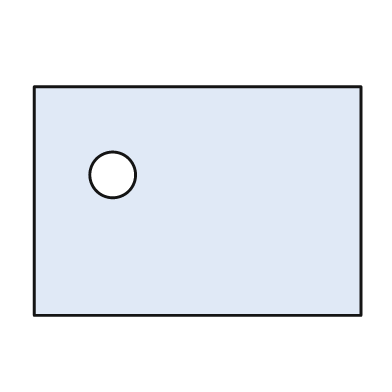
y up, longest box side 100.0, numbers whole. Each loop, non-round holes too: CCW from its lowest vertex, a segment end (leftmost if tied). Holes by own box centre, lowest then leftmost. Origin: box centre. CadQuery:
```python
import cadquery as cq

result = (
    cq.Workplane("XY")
    .moveTo(-50.0, -35.0)
    .lineTo(50.0, -35.0)
    .lineTo(50.0, 35.0)
    .lineTo(-50.0, 35.0)
    .close()
    .moveTo(-26.0, 8.0)
    .circle(7.0)
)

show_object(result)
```